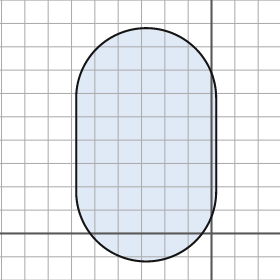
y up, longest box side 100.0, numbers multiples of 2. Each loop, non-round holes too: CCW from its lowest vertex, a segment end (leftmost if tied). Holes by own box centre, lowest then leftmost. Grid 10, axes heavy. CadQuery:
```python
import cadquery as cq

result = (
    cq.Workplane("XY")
    .moveTo(-58.0, 18.0)
    .threePointArc((-28.0, -12.0), (2.0, 18.0))
    .lineTo(2.0, 58.0)
    .threePointArc((-28.0, 88.0), (-58.0, 58.0))
    .close()
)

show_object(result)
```